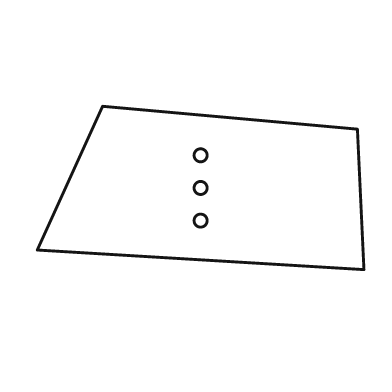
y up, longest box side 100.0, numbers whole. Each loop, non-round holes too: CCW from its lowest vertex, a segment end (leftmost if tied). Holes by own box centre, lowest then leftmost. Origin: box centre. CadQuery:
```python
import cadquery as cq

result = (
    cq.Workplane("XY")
    .moveTo(50.0, -25.0)
    .lineTo(48.0, 18.0)
    .lineTo(-30.0, 25.0)
    .lineTo(-50.0, -19.0)
    .close()
    .moveTo(0.0, -10.0)
    .circle(2.0)
    .moveTo(0.0, 0.0)
    .circle(2.0)
    .moveTo(0.0, 10.0)
    .circle(2.0)
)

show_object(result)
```